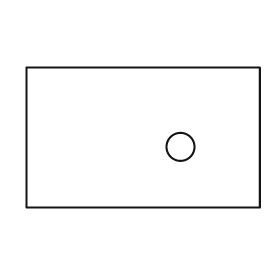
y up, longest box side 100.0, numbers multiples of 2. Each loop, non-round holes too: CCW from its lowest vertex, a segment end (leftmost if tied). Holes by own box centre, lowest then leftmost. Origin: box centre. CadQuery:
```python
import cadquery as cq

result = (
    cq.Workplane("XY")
    .moveTo(-50.0, -30.0)
    .lineTo(50.0, -30.0)
    .lineTo(50.0, 30.0)
    .lineTo(-50.0, 30.0)
    .close()
    .moveTo(16.0, -4.0)
    .circle(6.0)
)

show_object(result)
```